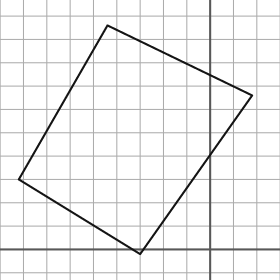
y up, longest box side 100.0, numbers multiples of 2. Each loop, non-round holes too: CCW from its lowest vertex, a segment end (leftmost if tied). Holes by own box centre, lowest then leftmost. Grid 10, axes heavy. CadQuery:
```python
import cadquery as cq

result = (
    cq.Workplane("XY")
    .moveTo(-30.0, -2.0)
    .lineTo(18.0, 66.0)
    .lineTo(-44.0, 96.0)
    .lineTo(-82.0, 30.0)
    .close()
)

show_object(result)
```